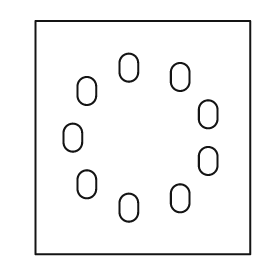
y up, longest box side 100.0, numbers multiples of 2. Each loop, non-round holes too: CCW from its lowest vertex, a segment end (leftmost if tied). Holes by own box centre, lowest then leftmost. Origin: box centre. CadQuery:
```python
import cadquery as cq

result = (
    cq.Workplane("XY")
    .moveTo(-46.0, -50.0)
    .lineTo(46.0, -50.0)
    .lineTo(46.0, 50.0)
    .lineTo(-46.0, 50.0)
    .close()
    .moveTo(-10.0, -32.0)
    .threePointArc((-6.0, -36.0), (-2.0, -32.0))
    .lineTo(-2.0, -28.0)
    .threePointArc((-6.0, -24.0), (-10.0, -28.0))
    .close()
    .moveTo(12.0, -28.0)
    .threePointArc((16.0, -32.0), (20.0, -28.0))
    .lineTo(20.0, -24.0)
    .threePointArc((16.0, -20.0), (12.0, -24.0))
    .close()
    .moveTo(-28.0, -22.0)
    .threePointArc((-24.0, -26.0), (-20.0, -22.0))
    .lineTo(-20.0, -18.0)
    .threePointArc((-24.0, -14.0), (-28.0, -18.0))
    .close()
    .moveTo(24.0, -12.0)
    .threePointArc((28.0, -16.0), (32.0, -12.0))
    .lineTo(32.0, -8.0)
    .threePointArc((28.0, -4.0), (24.0, -8.0))
    .close()
    .moveTo(-34.0, -2.0)
    .threePointArc((-30.0, -6.0), (-26.0, -2.0))
    .lineTo(-26.0, 2.0)
    .threePointArc((-30.0, 6.0), (-34.0, 2.0))
    .close()
    .moveTo(24.0, 8.0)
    .threePointArc((28.0, 4.0), (32.0, 8.0))
    .lineTo(32.0, 12.0)
    .threePointArc((28.0, 16.0), (24.0, 12.0))
    .close()
    .moveTo(-28.0, 18.0)
    .threePointArc((-24.0, 14.0), (-20.0, 18.0))
    .lineTo(-20.0, 22.0)
    .threePointArc((-24.0, 26.0), (-28.0, 22.0))
    .close()
    .moveTo(12.0, 24.0)
    .threePointArc((16.0, 20.0), (20.0, 24.0))
    .lineTo(20.0, 28.0)
    .threePointArc((16.0, 32.0), (12.0, 28.0))
    .close()
    .moveTo(-10.0, 28.0)
    .threePointArc((-6.0, 24.0), (-2.0, 28.0))
    .lineTo(-2.0, 32.0)
    .threePointArc((-6.0, 36.0), (-10.0, 32.0))
    .close()
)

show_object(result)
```